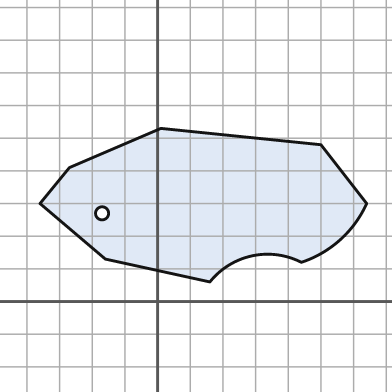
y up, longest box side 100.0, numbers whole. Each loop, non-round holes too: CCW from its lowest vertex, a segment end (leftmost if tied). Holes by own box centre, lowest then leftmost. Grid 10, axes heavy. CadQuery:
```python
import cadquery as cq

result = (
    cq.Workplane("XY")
    .moveTo(16.0, 6.0)
    .threePointArc((29.0, 14.0), (44.0, 12.0))
    .threePointArc((56.0, 19.0), (64.0, 30.0))
    .lineTo(50.0, 48.0)
    .lineTo(1.0, 53.0)
    .lineTo(-27.0, 41.0)
    .lineTo(-36.0, 30.0)
    .lineTo(-16.0, 13.0)
    .close()
    .moveTo(-17.0, 27.0)
    .circle(2.0)
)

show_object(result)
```